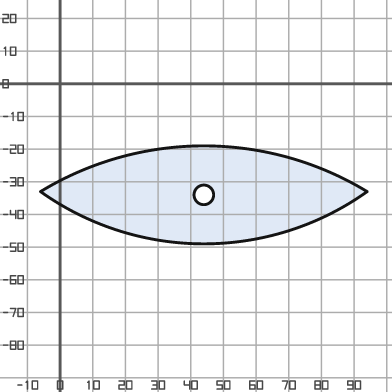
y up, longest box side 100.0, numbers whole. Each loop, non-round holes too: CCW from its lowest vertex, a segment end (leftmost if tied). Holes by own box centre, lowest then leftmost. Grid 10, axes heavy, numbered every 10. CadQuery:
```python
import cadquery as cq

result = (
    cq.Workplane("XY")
    .moveTo(-6.0, -33.0)
    .threePointArc((44.0, -49.0), (94.0, -33.0))
    .threePointArc((44.0, -19.0), (-6.0, -33.0))
    .close()
    .moveTo(44.0, -34.0)
    .circle(3.0)
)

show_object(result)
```